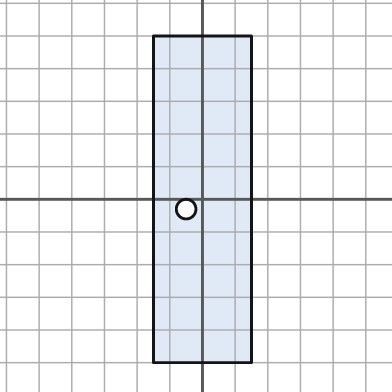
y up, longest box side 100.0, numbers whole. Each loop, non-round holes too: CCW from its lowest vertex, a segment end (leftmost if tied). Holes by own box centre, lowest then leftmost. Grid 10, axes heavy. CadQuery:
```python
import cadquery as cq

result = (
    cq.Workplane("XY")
    .moveTo(-15.0, -50.0)
    .lineTo(15.0, -50.0)
    .lineTo(15.0, 50.0)
    .lineTo(-15.0, 50.0)
    .close()
    .moveTo(-5.0, -3.0)
    .circle(3.0)
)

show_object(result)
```